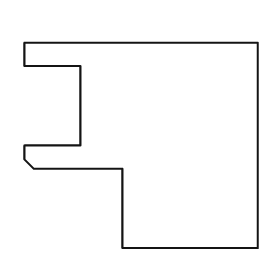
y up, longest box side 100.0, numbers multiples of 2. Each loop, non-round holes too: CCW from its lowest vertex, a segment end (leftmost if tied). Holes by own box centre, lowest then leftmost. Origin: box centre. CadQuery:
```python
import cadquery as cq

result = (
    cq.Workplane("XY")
    .moveTo(-8.0, -44.0)
    .lineTo(50.0, -44.0)
    .lineTo(50.0, 44.0)
    .lineTo(-50.0, 44.0)
    .lineTo(-50.0, 34.0)
    .lineTo(-26.0, 34.0)
    .lineTo(-26.0, 0.0)
    .lineTo(-50.0, 0.0)
    .lineTo(-50.0, -6.0)
    .lineTo(-46.0, -10.0)
    .lineTo(-8.0, -10.0)
    .close()
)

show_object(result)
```